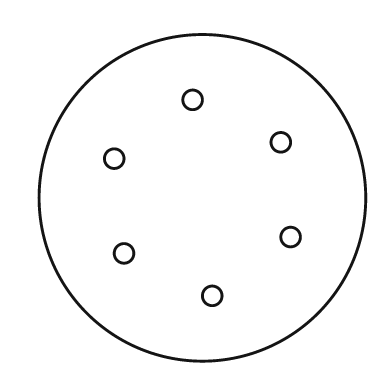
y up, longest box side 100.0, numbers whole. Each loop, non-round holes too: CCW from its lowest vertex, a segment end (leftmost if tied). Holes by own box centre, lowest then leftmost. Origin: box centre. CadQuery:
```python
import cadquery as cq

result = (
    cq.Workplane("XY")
    .moveTo(0.0, 0.0)
    .circle(50.0)
    .moveTo(3.0, -30.0)
    .circle(3.0)
    .moveTo(-24.0, -17.0)
    .circle(3.0)
    .moveTo(27.0, -12.0)
    .circle(3.0)
    .moveTo(-27.0, 12.0)
    .circle(3.0)
    .moveTo(24.0, 17.0)
    .circle(3.0)
    .moveTo(-3.0, 30.0)
    .circle(3.0)
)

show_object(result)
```